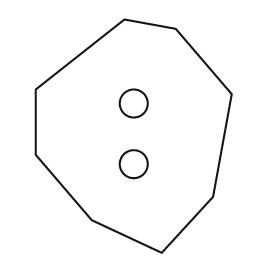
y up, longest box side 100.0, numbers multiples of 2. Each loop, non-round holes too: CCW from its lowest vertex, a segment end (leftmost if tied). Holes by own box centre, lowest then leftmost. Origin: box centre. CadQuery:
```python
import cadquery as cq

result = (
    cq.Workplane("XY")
    .moveTo(12.0, -50.0)
    .lineTo(34.0, -26.0)
    .lineTo(42.0, 18.0)
    .lineTo(18.0, 46.0)
    .lineTo(-4.0, 50.0)
    .lineTo(-42.0, 20.0)
    .lineTo(-42.0, -8.0)
    .lineTo(-18.0, -36.0)
    .close()
    .moveTo(0.0, -12.0)
    .circle(6.0)
    .moveTo(0.0, 14.0)
    .circle(6.0)
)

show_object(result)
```